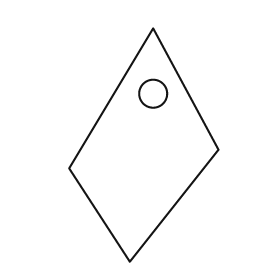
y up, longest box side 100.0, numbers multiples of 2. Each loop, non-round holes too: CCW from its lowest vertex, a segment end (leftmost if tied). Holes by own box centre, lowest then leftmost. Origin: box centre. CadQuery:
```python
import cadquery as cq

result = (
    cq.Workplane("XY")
    .moveTo(-6.0, -50.0)
    .lineTo(32.0, -2.0)
    .lineTo(4.0, 50.0)
    .lineTo(-32.0, -10.0)
    .close()
    .moveTo(4.0, 22.0)
    .circle(6.0)
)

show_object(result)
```